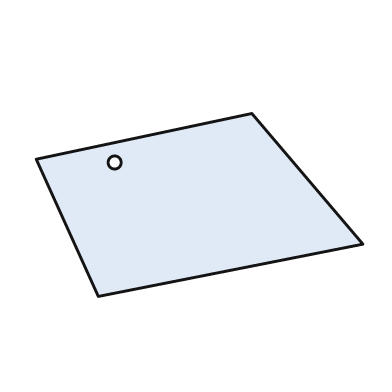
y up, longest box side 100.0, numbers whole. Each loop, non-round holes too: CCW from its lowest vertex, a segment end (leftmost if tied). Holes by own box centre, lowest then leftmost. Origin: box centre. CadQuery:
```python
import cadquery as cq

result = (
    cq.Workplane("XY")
    .moveTo(-31.0, -28.0)
    .lineTo(50.0, -12.0)
    .lineTo(16.0, 28.0)
    .lineTo(-50.0, 14.0)
    .close()
    .moveTo(-26.0, 13.0)
    .circle(2.0)
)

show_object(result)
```